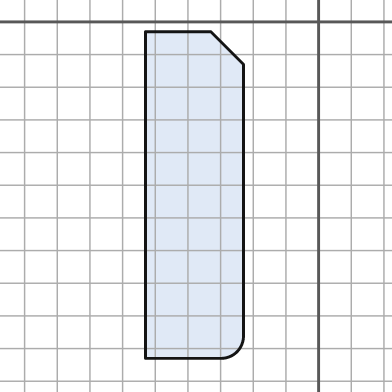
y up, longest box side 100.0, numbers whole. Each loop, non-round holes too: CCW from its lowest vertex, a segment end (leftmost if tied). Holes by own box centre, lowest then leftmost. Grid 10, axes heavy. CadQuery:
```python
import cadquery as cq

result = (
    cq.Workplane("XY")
    .moveTo(-53.0, -103.0)
    .lineTo(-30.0, -103.0)
    .threePointArc((-25.0, -101.0), (-23.0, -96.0))
    .lineTo(-23.0, -13.0)
    .lineTo(-33.0, -3.0)
    .lineTo(-53.0, -3.0)
    .close()
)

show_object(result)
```